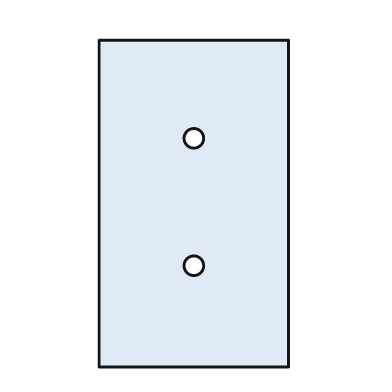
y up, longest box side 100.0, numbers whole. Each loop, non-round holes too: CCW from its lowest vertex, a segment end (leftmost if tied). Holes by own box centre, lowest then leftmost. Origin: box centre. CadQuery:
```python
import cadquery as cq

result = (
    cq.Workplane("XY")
    .moveTo(-29.0, -50.0)
    .lineTo(29.0, -50.0)
    .lineTo(29.0, 50.0)
    .lineTo(-29.0, 50.0)
    .close()
    .moveTo(0.0, -19.0)
    .circle(3.0)
    .moveTo(0.0, 20.0)
    .circle(3.0)
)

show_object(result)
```